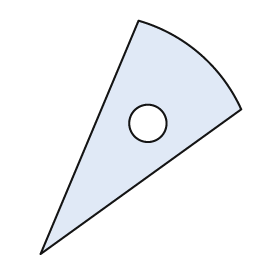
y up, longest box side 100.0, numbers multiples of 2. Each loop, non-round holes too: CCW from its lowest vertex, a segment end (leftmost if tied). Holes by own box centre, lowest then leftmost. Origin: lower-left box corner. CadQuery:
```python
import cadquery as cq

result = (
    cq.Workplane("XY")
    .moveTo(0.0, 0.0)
    .lineTo(86.0, 62.0)
    .threePointArc((68.0, 86.0), (42.0, 100.0))
    .close()
    .moveTo(46.0, 56.0)
    .circle(8.0)
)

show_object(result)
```